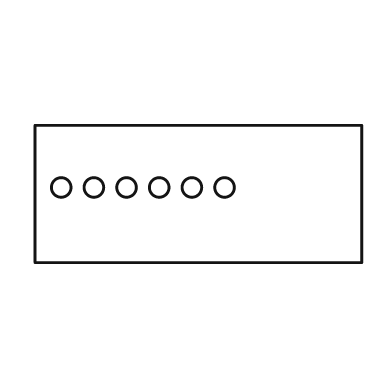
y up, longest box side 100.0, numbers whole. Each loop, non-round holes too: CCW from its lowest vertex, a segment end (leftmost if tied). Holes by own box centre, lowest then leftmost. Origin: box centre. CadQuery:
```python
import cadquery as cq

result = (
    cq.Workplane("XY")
    .moveTo(-50.0, -21.0)
    .lineTo(50.0, -21.0)
    .lineTo(50.0, 21.0)
    .lineTo(-50.0, 21.0)
    .close()
    .moveTo(-42.0, 2.0)
    .circle(3.0)
    .moveTo(-32.0, 2.0)
    .circle(3.0)
    .moveTo(-22.0, 2.0)
    .circle(3.0)
    .moveTo(-12.0, 2.0)
    .circle(3.0)
    .moveTo(-2.0, 2.0)
    .circle(3.0)
    .moveTo(8.0, 2.0)
    .circle(3.0)
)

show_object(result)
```